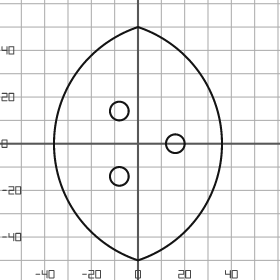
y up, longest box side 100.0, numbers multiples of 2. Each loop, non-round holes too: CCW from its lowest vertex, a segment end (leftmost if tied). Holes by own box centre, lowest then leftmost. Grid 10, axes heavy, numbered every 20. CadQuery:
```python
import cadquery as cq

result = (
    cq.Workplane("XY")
    .moveTo(0.0, -50.0)
    .threePointArc((36.0, 0.0), (0.0, 50.0))
    .threePointArc((-36.0, 0.0), (0.0, -50.0))
    .close()
    .moveTo(-8.0, -14.0)
    .circle(4.0)
    .moveTo(16.0, 0.0)
    .circle(4.0)
    .moveTo(-8.0, 14.0)
    .circle(4.0)
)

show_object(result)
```